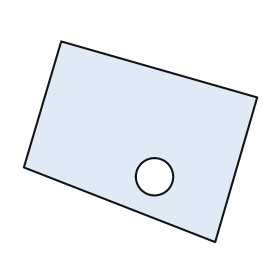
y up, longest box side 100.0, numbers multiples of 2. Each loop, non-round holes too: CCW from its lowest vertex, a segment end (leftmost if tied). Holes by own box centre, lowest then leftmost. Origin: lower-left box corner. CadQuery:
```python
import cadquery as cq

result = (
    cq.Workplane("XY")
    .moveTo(82.0, 0.0)
    .lineTo(100.0, 62.0)
    .lineTo(16.0, 86.0)
    .lineTo(0.0, 32.0)
    .close()
    .moveTo(56.0, 28.0)
    .circle(8.0)
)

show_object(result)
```